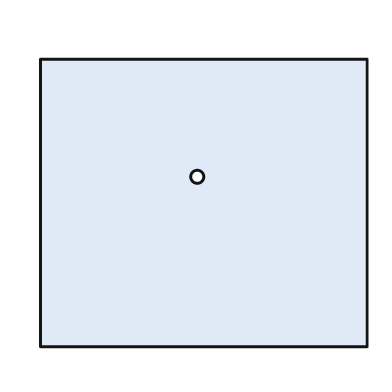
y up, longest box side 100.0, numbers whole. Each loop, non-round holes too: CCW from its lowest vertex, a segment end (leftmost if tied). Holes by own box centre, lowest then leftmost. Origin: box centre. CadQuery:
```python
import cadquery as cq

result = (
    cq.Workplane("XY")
    .moveTo(-50.0, -44.0)
    .lineTo(50.0, -44.0)
    .lineTo(50.0, 44.0)
    .lineTo(-50.0, 44.0)
    .close()
    .moveTo(-2.0, 8.0)
    .circle(2.0)
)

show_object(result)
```